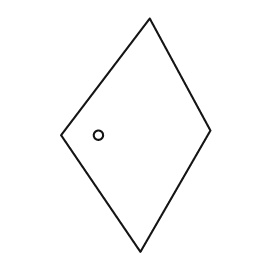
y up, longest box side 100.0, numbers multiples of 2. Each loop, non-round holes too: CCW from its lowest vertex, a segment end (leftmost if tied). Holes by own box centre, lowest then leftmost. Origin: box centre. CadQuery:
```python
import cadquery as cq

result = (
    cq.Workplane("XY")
    .moveTo(2.0, -50.0)
    .lineTo(32.0, 2.0)
    .lineTo(6.0, 50.0)
    .lineTo(-32.0, 0.0)
    .close()
    .moveTo(-16.0, 0.0)
    .circle(2.0)
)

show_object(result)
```